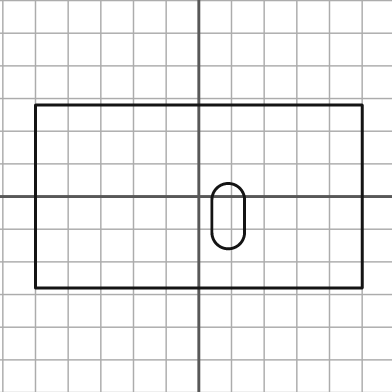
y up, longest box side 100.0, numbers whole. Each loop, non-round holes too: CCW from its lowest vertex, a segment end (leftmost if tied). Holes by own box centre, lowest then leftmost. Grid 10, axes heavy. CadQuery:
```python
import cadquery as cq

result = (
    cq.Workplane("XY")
    .moveTo(-50.0, -28.0)
    .lineTo(50.0, -28.0)
    .lineTo(50.0, 28.0)
    .lineTo(-50.0, 28.0)
    .close()
    .moveTo(4.0, -11.0)
    .threePointArc((9.0, -16.0), (14.0, -11.0))
    .lineTo(14.0, -1.0)
    .threePointArc((9.0, 4.0), (4.0, -1.0))
    .close()
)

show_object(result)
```